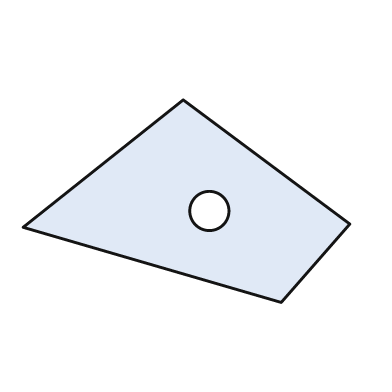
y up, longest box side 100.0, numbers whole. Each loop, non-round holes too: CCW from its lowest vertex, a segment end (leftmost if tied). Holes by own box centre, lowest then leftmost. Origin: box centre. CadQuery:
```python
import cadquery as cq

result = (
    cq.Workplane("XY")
    .moveTo(29.0, -31.0)
    .lineTo(50.0, -7.0)
    .lineTo(-1.0, 31.0)
    .lineTo(-50.0, -8.0)
    .close()
    .moveTo(7.0, -3.0)
    .circle(6.0)
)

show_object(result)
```